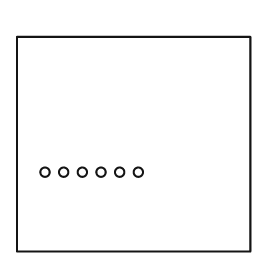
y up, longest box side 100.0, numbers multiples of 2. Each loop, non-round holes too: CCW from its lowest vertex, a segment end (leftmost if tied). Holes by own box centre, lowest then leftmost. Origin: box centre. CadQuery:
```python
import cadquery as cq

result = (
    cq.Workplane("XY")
    .moveTo(-50.0, -46.0)
    .lineTo(50.0, -46.0)
    .lineTo(50.0, 46.0)
    .lineTo(-50.0, 46.0)
    .close()
    .moveTo(-38.0, -12.0)
    .circle(2.0)
    .moveTo(-30.0, -12.0)
    .circle(2.0)
    .moveTo(-22.0, -12.0)
    .circle(2.0)
    .moveTo(-14.0, -12.0)
    .circle(2.0)
    .moveTo(-6.0, -12.0)
    .circle(2.0)
    .moveTo(2.0, -12.0)
    .circle(2.0)
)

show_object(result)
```